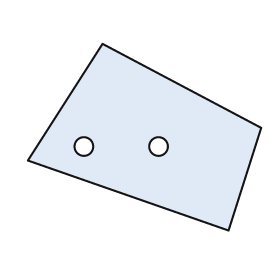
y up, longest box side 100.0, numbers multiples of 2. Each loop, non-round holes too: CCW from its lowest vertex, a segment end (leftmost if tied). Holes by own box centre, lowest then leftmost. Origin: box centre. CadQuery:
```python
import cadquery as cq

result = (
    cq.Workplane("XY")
    .moveTo(36.0, -40.0)
    .lineTo(50.0, 4.0)
    .lineTo(-18.0, 40.0)
    .lineTo(-50.0, -10.0)
    .close()
    .moveTo(-26.0, -4.0)
    .circle(4.0)
    .moveTo(6.0, -4.0)
    .circle(4.0)
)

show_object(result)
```